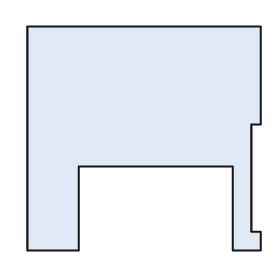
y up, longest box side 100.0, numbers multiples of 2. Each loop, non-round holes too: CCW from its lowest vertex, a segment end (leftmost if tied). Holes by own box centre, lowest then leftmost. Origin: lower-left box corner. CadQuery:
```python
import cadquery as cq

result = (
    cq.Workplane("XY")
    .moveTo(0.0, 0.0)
    .lineTo(22.0, 0.0)
    .lineTo(22.0, 36.0)
    .lineTo(88.0, 36.0)
    .lineTo(88.0, 0.0)
    .lineTo(100.0, 0.0)
    .lineTo(100.0, 8.0)
    .lineTo(96.0, 8.0)
    .lineTo(96.0, 54.0)
    .lineTo(100.0, 54.0)
    .lineTo(100.0, 96.0)
    .lineTo(0.0, 96.0)
    .close()
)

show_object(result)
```